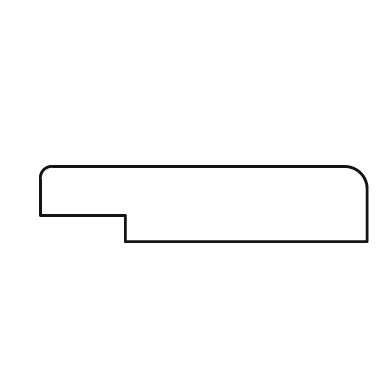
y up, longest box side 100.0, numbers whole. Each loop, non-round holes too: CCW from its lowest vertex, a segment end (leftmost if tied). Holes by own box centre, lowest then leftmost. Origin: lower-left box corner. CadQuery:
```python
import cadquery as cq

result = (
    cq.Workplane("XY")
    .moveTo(26.0, 0.0)
    .lineTo(100.0, 0.0)
    .lineTo(100.0, 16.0)
    .threePointArc((98.0, 21.0), (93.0, 23.0))
    .lineTo(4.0, 23.0)
    .threePointArc((1.0, 22.0), (0.0, 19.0))
    .lineTo(0.0, 8.0)
    .lineTo(26.0, 8.0)
    .close()
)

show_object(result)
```